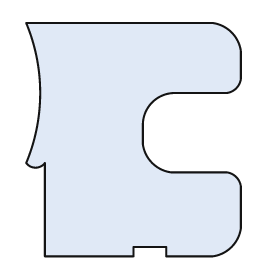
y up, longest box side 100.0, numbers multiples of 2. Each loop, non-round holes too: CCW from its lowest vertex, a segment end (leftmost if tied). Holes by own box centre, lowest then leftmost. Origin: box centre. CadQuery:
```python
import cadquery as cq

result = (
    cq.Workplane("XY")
    .moveTo(-38.0, -50.0)
    .lineTo(0.0, -50.0)
    .lineTo(0.0, -46.0)
    .lineTo(14.0, -46.0)
    .lineTo(14.0, -50.0)
    .lineTo(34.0, -50.0)
    .threePointArc((42.0, -46.0), (46.0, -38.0))
    .lineTo(46.0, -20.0)
    .threePointArc((44.0, -16.0), (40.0, -14.0))
    .lineTo(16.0, -14.0)
    .threePointArc((8.0, -10.0), (4.0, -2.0))
    .lineTo(4.0, 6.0)
    .threePointArc((8.0, 16.0), (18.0, 20.0))
    .lineTo(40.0, 20.0)
    .threePointArc((44.0, 22.0), (46.0, 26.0))
    .lineTo(46.0, 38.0)
    .threePointArc((42.0, 46.0), (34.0, 50.0))
    .lineTo(-46.0, 50.0)
    .threePointArc((-40.0, 20.0), (-46.0, -10.0))
    .threePointArc((-42.0, -12.0), (-38.0, -10.0))
    .close()
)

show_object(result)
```